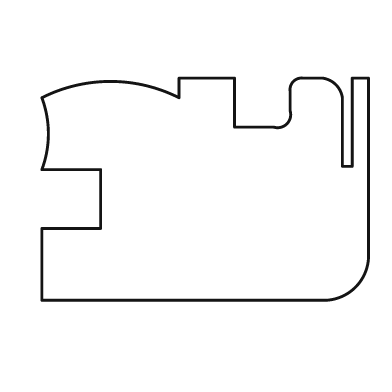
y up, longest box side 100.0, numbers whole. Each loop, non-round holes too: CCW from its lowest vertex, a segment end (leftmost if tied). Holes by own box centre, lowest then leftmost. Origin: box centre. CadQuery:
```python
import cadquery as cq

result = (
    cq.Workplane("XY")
    .moveTo(-50.0, -34.0)
    .lineTo(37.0, -34.0)
    .threePointArc((46.0, -30.0), (50.0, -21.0))
    .lineTo(50.0, 34.0)
    .lineTo(45.0, 34.0)
    .lineTo(45.0, 7.0)
    .lineTo(42.0, 7.0)
    .lineTo(42.0, 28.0)
    .threePointArc((40.0, 32.0), (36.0, 34.0))
    .lineTo(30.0, 34.0)
    .threePointArc((27.0, 33.0), (26.0, 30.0))
    .lineTo(26.0, 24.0)
    .threePointArc((25.0, 20.0), (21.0, 19.0))
    .lineTo(9.0, 19.0)
    .lineTo(9.0, 34.0)
    .lineTo(-8.0, 34.0)
    .lineTo(-8.0, 28.0)
    .threePointArc((-29.0, 33.0), (-50.0, 28.0))
    .threePointArc((-48.0, 17.0), (-50.0, 6.0))
    .lineTo(-32.0, 6.0)
    .lineTo(-32.0, -12.0)
    .lineTo(-50.0, -12.0)
    .close()
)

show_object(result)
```